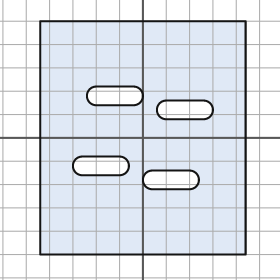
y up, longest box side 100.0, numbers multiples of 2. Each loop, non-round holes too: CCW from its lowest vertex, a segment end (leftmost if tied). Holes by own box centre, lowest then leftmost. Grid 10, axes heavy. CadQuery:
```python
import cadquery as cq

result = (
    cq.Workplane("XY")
    .moveTo(-44.0, -50.0)
    .lineTo(44.0, -50.0)
    .lineTo(44.0, 50.0)
    .lineTo(-44.0, 50.0)
    .close()
    .moveTo(4.0, -22.0)
    .lineTo(20.0, -22.0)
    .threePointArc((24.0, -18.0), (20.0, -14.0))
    .lineTo(4.0, -14.0)
    .threePointArc((0.0, -18.0), (4.0, -22.0))
    .close()
    .moveTo(-26.0, -16.0)
    .lineTo(-10.0, -16.0)
    .threePointArc((-6.0, -12.0), (-10.0, -8.0))
    .lineTo(-26.0, -8.0)
    .threePointArc((-30.0, -12.0), (-26.0, -16.0))
    .close()
    .moveTo(10.0, 8.0)
    .lineTo(26.0, 8.0)
    .threePointArc((30.0, 12.0), (26.0, 16.0))
    .lineTo(10.0, 16.0)
    .threePointArc((6.0, 12.0), (10.0, 8.0))
    .close()
    .moveTo(-20.0, 14.0)
    .lineTo(-4.0, 14.0)
    .threePointArc((0.0, 18.0), (-4.0, 22.0))
    .lineTo(-20.0, 22.0)
    .threePointArc((-24.0, 18.0), (-20.0, 14.0))
    .close()
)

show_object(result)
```